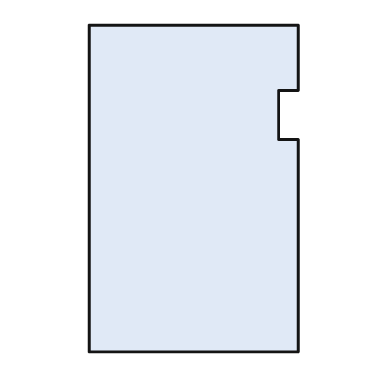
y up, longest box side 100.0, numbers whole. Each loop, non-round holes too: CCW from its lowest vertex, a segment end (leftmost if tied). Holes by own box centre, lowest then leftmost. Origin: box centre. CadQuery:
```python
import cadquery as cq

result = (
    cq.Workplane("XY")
    .moveTo(-32.0, -50.0)
    .lineTo(32.0, -50.0)
    .lineTo(32.0, 15.0)
    .lineTo(26.0, 15.0)
    .lineTo(26.0, 30.0)
    .lineTo(32.0, 30.0)
    .lineTo(32.0, 50.0)
    .lineTo(-32.0, 50.0)
    .close()
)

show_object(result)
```